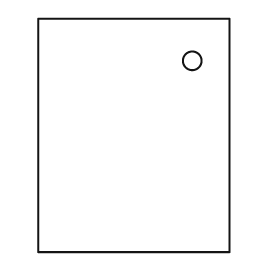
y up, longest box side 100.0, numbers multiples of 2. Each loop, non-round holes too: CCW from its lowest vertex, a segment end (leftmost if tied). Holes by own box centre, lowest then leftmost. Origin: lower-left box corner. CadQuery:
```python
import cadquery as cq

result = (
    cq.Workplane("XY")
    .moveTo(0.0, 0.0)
    .lineTo(82.0, 0.0)
    .lineTo(82.0, 100.0)
    .lineTo(0.0, 100.0)
    .close()
    .moveTo(66.0, 82.0)
    .circle(4.0)
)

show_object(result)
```